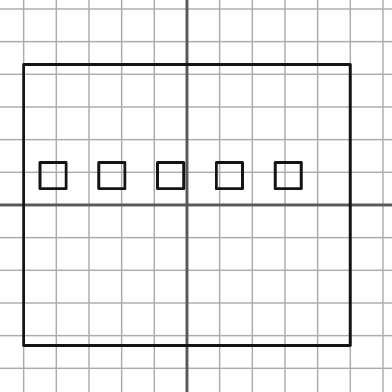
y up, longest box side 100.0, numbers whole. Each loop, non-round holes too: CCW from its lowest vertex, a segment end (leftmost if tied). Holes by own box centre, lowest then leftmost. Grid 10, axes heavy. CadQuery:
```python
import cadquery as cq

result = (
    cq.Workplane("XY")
    .moveTo(-50.0, -43.0)
    .lineTo(50.0, -43.0)
    .lineTo(50.0, 43.0)
    .lineTo(-50.0, 43.0)
    .close()
    .moveTo(-45.0, 5.0)
    .lineTo(-37.0, 5.0)
    .lineTo(-37.0, 13.0)
    .lineTo(-45.0, 13.0)
    .close()
    .moveTo(-27.0, 5.0)
    .lineTo(-19.0, 5.0)
    .lineTo(-19.0, 13.0)
    .lineTo(-27.0, 13.0)
    .close()
    .moveTo(-9.0, 5.0)
    .lineTo(-1.0, 5.0)
    .lineTo(-1.0, 13.0)
    .lineTo(-9.0, 13.0)
    .close()
    .moveTo(9.0, 5.0)
    .lineTo(17.0, 5.0)
    .lineTo(17.0, 13.0)
    .lineTo(9.0, 13.0)
    .close()
    .moveTo(27.0, 5.0)
    .lineTo(35.0, 5.0)
    .lineTo(35.0, 13.0)
    .lineTo(27.0, 13.0)
    .close()
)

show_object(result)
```